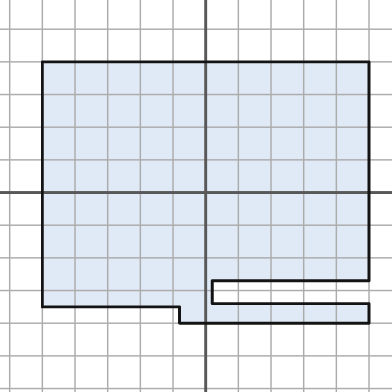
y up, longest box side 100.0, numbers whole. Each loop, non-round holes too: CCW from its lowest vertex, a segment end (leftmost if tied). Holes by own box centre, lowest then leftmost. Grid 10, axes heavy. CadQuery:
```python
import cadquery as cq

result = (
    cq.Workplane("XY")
    .moveTo(-8.0, -40.0)
    .lineTo(50.0, -40.0)
    .lineTo(50.0, -34.0)
    .lineTo(2.0, -34.0)
    .lineTo(2.0, -27.0)
    .lineTo(50.0, -27.0)
    .lineTo(50.0, 40.0)
    .lineTo(-50.0, 40.0)
    .lineTo(-50.0, -35.0)
    .lineTo(-8.0, -35.0)
    .close()
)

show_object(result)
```